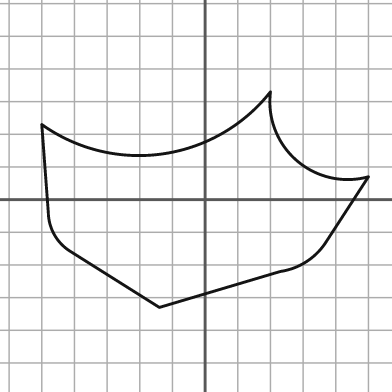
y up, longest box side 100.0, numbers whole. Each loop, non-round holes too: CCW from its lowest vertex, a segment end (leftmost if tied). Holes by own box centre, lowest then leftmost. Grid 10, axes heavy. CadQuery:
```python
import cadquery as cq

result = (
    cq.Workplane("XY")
    .moveTo(-14.0, -33.0)
    .lineTo(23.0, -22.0)
    .threePointArc((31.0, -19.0), (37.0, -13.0))
    .lineTo(50.0, 7.0)
    .threePointArc((28.0, 12.0), (20.0, 33.0))
    .threePointArc((-13.0, 14.0), (-50.0, 23.0))
    .lineTo(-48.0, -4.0)
    .threePointArc((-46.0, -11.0), (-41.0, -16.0))
    .close()
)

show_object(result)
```